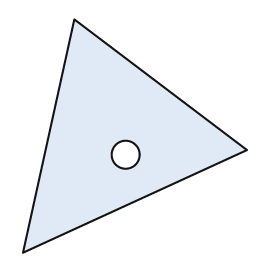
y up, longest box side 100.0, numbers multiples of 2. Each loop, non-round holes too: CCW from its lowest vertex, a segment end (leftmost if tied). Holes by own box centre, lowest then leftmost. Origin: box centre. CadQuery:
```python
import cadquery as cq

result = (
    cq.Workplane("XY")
    .moveTo(-48.0, -50.0)
    .lineTo(48.0, -6.0)
    .lineTo(-26.0, 50.0)
    .close()
    .moveTo(-4.0, -8.0)
    .circle(6.0)
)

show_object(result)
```